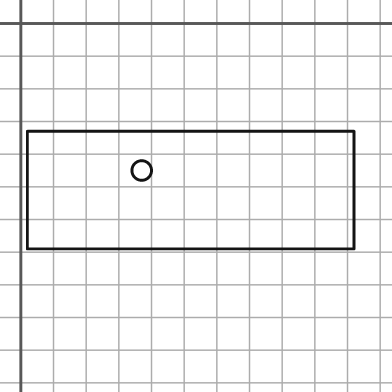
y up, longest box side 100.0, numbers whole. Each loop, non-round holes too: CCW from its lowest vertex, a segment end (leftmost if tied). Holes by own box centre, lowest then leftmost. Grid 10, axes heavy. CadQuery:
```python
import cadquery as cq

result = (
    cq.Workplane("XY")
    .moveTo(2.0, -69.0)
    .lineTo(102.0, -69.0)
    .lineTo(102.0, -33.0)
    .lineTo(2.0, -33.0)
    .close()
    .moveTo(37.0, -45.0)
    .circle(3.0)
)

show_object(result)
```